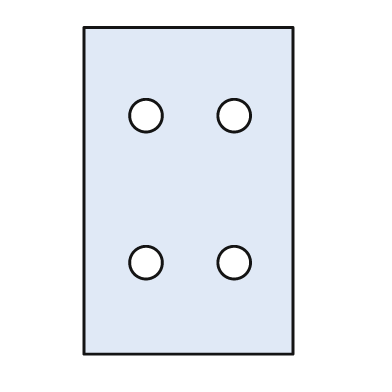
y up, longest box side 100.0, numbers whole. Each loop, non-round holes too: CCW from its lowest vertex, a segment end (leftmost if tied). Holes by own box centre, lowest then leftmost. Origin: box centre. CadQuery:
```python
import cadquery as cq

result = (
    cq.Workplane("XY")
    .moveTo(-32.0, -50.0)
    .lineTo(32.0, -50.0)
    .lineTo(32.0, 50.0)
    .lineTo(-32.0, 50.0)
    .close()
    .moveTo(-13.0, -22.0)
    .circle(5.0)
    .moveTo(14.0, -22.0)
    .circle(5.0)
    .moveTo(-13.0, 23.0)
    .circle(5.0)
    .moveTo(14.0, 23.0)
    .circle(5.0)
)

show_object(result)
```